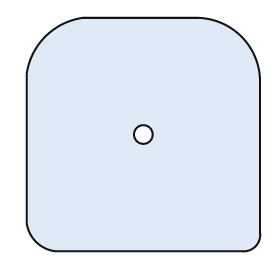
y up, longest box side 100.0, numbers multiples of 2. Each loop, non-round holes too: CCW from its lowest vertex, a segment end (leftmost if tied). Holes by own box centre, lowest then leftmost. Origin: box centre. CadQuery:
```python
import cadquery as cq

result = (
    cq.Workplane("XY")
    .moveTo(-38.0, -50.0)
    .lineTo(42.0, -50.0)
    .threePointArc((48.0, -48.0), (50.0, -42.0))
    .lineTo(50.0, 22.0)
    .threePointArc((42.0, 42.0), (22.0, 50.0))
    .lineTo(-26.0, 50.0)
    .threePointArc((-42.0, 42.0), (-50.0, 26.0))
    .lineTo(-50.0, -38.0)
    .threePointArc((-46.0, -46.0), (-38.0, -50.0))
    .close()
    .moveTo(0.0, 0.0)
    .circle(4.0)
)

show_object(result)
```